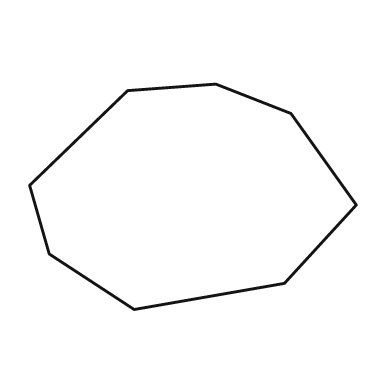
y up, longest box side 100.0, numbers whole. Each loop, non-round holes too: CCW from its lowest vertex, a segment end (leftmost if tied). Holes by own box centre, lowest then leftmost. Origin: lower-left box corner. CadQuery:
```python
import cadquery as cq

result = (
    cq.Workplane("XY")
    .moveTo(32.0, 0.0)
    .lineTo(78.0, 8.0)
    .lineTo(100.0, 32.0)
    .lineTo(80.0, 60.0)
    .lineTo(57.0, 69.0)
    .lineTo(30.0, 67.0)
    .lineTo(0.0, 38.0)
    .lineTo(6.0, 17.0)
    .close()
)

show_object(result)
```